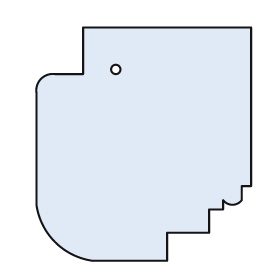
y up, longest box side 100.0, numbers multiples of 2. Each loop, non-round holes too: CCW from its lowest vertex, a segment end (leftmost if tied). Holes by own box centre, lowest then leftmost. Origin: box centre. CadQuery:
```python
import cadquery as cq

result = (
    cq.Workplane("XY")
    .moveTo(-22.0, -50.0)
    .lineTo(10.0, -50.0)
    .lineTo(10.0, -38.0)
    .lineTo(28.0, -38.0)
    .lineTo(28.0, -28.0)
    .lineTo(34.0, -28.0)
    .lineTo(34.0, -24.0)
    .threePointArc((38.0, -26.0), (42.0, -24.0))
    .lineTo(42.0, -18.0)
    .lineTo(46.0, -18.0)
    .lineTo(46.0, 50.0)
    .lineTo(-26.0, 50.0)
    .lineTo(-26.0, 30.0)
    .lineTo(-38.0, 30.0)
    .threePointArc((-44.0, 28.0), (-46.0, 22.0))
    .lineTo(-46.0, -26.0)
    .threePointArc((-38.0, -42.0), (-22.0, -50.0))
    .close()
    .moveTo(-12.0, 32.0)
    .circle(2.0)
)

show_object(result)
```